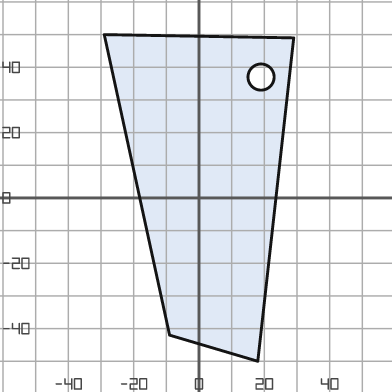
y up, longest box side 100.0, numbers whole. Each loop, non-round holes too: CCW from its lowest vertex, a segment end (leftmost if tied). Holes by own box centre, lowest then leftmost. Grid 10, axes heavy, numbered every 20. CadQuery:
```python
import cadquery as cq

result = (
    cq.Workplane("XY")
    .moveTo(18.0, -50.0)
    .lineTo(29.0, 49.0)
    .lineTo(-29.0, 50.0)
    .lineTo(-9.0, -42.0)
    .close()
    .moveTo(19.0, 37.0)
    .circle(4.0)
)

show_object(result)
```